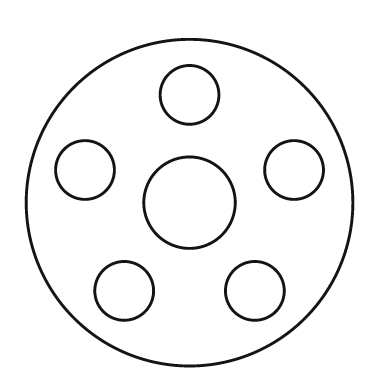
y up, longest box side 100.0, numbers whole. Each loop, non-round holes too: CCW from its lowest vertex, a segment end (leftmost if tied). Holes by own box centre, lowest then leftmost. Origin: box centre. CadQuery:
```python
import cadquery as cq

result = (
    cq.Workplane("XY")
    .moveTo(0.0, 0.0)
    .circle(50.0)
    .moveTo(-20.0, -27.0)
    .circle(9.0)
    .moveTo(20.0, -27.0)
    .circle(9.0)
    .moveTo(0.0, 0.0)
    .circle(14.0)
    .moveTo(-32.0, 10.0)
    .circle(9.0)
    .moveTo(32.0, 10.0)
    .circle(9.0)
    .moveTo(0.0, 33.0)
    .circle(9.0)
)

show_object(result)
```